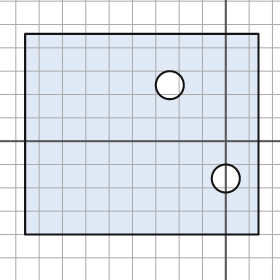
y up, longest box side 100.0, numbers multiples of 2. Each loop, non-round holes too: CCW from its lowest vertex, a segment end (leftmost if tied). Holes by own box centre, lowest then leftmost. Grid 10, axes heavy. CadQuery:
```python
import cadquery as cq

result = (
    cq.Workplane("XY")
    .moveTo(-86.0, -40.0)
    .lineTo(14.0, -40.0)
    .lineTo(14.0, 46.0)
    .lineTo(-86.0, 46.0)
    .close()
    .moveTo(0.0, -16.0)
    .circle(6.0)
    .moveTo(-24.0, 24.0)
    .circle(6.0)
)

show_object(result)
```